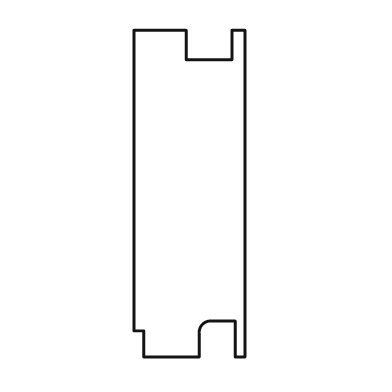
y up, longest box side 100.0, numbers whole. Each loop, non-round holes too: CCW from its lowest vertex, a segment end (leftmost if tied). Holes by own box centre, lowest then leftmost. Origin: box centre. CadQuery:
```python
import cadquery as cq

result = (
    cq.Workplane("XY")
    .moveTo(-14.0, -50.0)
    .lineTo(3.0, -50.0)
    .lineTo(3.0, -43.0)
    .threePointArc((4.0, -40.0), (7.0, -39.0))
    .lineTo(14.0, -39.0)
    .lineTo(14.0, -50.0)
    .lineTo(17.0, -50.0)
    .lineTo(17.0, 50.0)
    .lineTo(13.0, 50.0)
    .lineTo(13.0, 41.0)
    .lineTo(-1.0, 41.0)
    .lineTo(-1.0, 50.0)
    .lineTo(-17.0, 50.0)
    .lineTo(-17.0, -42.0)
    .lineTo(-14.0, -42.0)
    .close()
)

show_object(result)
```